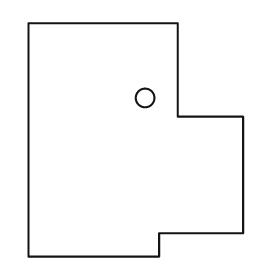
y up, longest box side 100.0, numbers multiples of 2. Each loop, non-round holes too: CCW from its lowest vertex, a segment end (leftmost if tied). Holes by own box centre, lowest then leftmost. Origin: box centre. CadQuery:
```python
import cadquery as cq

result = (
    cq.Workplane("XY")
    .moveTo(-46.0, -50.0)
    .lineTo(10.0, -50.0)
    .lineTo(10.0, -40.0)
    .lineTo(46.0, -40.0)
    .lineTo(46.0, 10.0)
    .lineTo(18.0, 10.0)
    .lineTo(18.0, 50.0)
    .lineTo(-46.0, 50.0)
    .close()
    .moveTo(4.0, 18.0)
    .circle(4.0)
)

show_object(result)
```